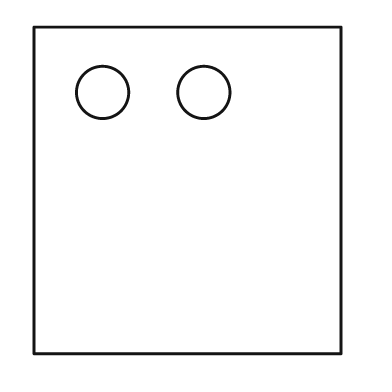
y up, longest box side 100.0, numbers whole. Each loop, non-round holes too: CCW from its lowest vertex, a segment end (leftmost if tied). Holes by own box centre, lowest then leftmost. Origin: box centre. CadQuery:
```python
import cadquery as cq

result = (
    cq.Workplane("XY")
    .moveTo(-47.0, -50.0)
    .lineTo(47.0, -50.0)
    .lineTo(47.0, 50.0)
    .lineTo(-47.0, 50.0)
    .close()
    .moveTo(-26.0, 30.0)
    .circle(8.0)
    .moveTo(5.0, 30.0)
    .circle(8.0)
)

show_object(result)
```